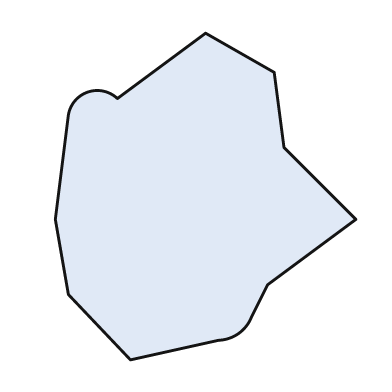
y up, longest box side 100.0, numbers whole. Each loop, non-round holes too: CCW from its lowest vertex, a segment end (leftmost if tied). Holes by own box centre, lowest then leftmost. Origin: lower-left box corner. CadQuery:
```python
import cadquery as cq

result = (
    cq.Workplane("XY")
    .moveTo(23.0, 0.0)
    .lineTo(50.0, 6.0)
    .threePointArc((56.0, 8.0), (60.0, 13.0))
    .lineTo(65.0, 23.0)
    .lineTo(92.0, 43.0)
    .lineTo(70.0, 65.0)
    .lineTo(67.0, 88.0)
    .lineTo(46.0, 100.0)
    .lineTo(19.0, 80.0)
    .threePointArc((10.0, 82.0), (4.0, 75.0))
    .lineTo(0.0, 43.0)
    .lineTo(4.0, 20.0)
    .close()
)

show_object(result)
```